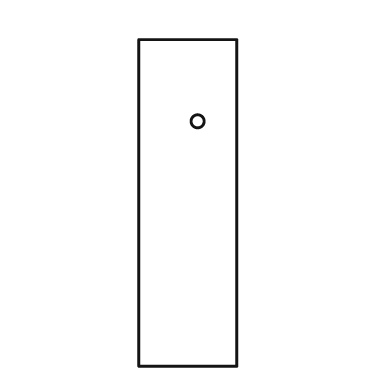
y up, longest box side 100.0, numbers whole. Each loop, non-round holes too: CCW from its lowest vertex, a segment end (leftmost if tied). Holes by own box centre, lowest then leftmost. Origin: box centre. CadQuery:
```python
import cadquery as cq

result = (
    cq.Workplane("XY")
    .moveTo(-15.0, -50.0)
    .lineTo(15.0, -50.0)
    .lineTo(15.0, 50.0)
    .lineTo(-15.0, 50.0)
    .close()
    .moveTo(3.0, 25.0)
    .circle(2.0)
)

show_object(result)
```